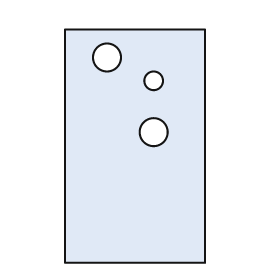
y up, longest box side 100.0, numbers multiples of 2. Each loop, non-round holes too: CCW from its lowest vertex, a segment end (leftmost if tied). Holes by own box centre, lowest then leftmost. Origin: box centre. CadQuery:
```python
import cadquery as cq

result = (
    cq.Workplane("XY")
    .moveTo(-30.0, -50.0)
    .lineTo(30.0, -50.0)
    .lineTo(30.0, 50.0)
    .lineTo(-30.0, 50.0)
    .close()
    .moveTo(8.0, 6.0)
    .circle(6.0)
    .moveTo(8.0, 28.0)
    .circle(4.0)
    .moveTo(-12.0, 38.0)
    .circle(6.0)
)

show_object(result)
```